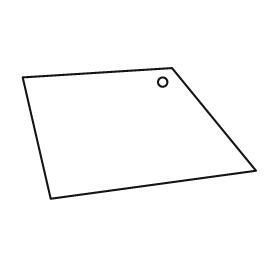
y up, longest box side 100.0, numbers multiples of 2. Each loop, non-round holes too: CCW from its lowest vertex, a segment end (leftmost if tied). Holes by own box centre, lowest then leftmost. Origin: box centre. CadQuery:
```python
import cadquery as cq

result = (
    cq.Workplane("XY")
    .moveTo(-38.0, -28.0)
    .lineTo(50.0, -16.0)
    .lineTo(14.0, 28.0)
    .lineTo(-50.0, 24.0)
    .close()
    .moveTo(10.0, 22.0)
    .circle(2.0)
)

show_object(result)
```